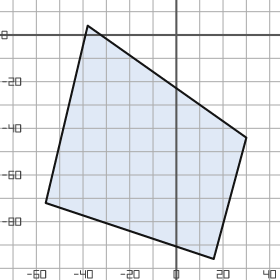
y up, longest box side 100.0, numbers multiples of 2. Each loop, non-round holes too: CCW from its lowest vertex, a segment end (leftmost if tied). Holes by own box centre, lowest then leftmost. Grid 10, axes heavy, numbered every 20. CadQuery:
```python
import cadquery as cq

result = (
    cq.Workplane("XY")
    .moveTo(16.0, -96.0)
    .lineTo(30.0, -44.0)
    .lineTo(-38.0, 4.0)
    .lineTo(-56.0, -72.0)
    .close()
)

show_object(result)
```